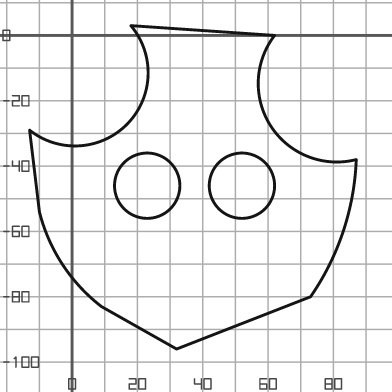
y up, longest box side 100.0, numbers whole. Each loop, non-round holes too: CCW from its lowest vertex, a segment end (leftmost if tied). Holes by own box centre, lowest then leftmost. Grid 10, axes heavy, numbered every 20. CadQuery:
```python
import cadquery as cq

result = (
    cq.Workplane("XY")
    .moveTo(32.0, -96.0)
    .lineTo(73.0, -80.0)
    .threePointArc((83.0, -60.0), (87.0, -38.0))
    .threePointArc((61.0, -28.0), (62.0, 0.0))
    .lineTo(18.0, 3.0)
    .threePointArc((17.0, -27.0), (-13.0, -29.0))
    .lineTo(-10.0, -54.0)
    .threePointArc((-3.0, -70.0), (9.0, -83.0))
    .close()
    .moveTo(23.0, -46.0)
    .circle(10.0)
    .moveTo(52.0, -46.0)
    .circle(10.0)
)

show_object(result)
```